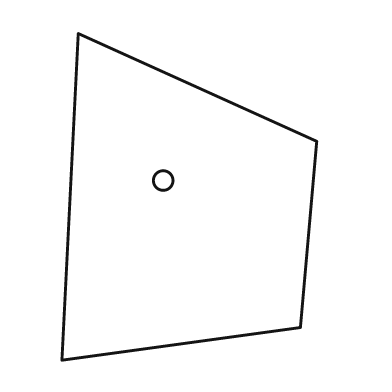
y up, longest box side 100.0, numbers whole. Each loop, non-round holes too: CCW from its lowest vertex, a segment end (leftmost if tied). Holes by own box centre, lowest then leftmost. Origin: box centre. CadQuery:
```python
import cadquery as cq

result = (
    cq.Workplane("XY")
    .moveTo(-39.0, -50.0)
    .lineTo(34.0, -40.0)
    .lineTo(39.0, 17.0)
    .lineTo(-34.0, 50.0)
    .close()
    .moveTo(-8.0, 5.0)
    .circle(3.0)
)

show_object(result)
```